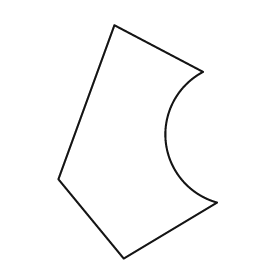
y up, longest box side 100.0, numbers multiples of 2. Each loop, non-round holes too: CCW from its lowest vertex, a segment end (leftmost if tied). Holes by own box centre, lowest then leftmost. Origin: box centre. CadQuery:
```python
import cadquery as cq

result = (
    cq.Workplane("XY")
    .moveTo(-6.0, -50.0)
    .lineTo(34.0, -26.0)
    .threePointArc((12.0, 0.0), (28.0, 30.0))
    .lineTo(-10.0, 50.0)
    .lineTo(-34.0, -16.0)
    .close()
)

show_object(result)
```